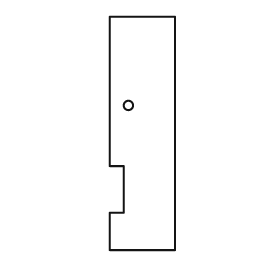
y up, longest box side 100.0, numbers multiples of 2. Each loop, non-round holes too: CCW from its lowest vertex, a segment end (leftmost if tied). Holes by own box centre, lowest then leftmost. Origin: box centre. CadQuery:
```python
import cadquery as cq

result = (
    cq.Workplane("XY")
    .moveTo(-14.0, -50.0)
    .lineTo(14.0, -50.0)
    .lineTo(14.0, 50.0)
    .lineTo(-14.0, 50.0)
    .lineTo(-14.0, -14.0)
    .lineTo(-8.0, -14.0)
    .lineTo(-8.0, -34.0)
    .lineTo(-14.0, -34.0)
    .close()
    .moveTo(-6.0, 12.0)
    .circle(2.0)
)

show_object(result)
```